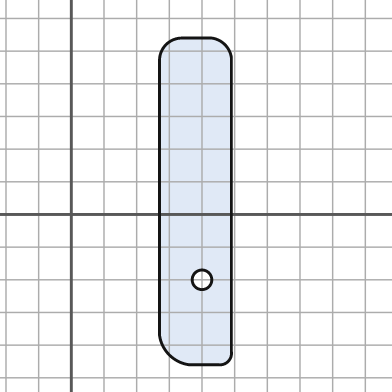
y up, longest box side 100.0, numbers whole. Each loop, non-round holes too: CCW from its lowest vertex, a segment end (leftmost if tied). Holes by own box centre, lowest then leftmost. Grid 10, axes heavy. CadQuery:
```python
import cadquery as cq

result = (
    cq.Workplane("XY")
    .moveTo(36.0, -46.0)
    .lineTo(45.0, -46.0)
    .threePointArc((48.0, -45.0), (49.0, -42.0))
    .lineTo(49.0, 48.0)
    .threePointArc((47.0, 52.0), (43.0, 54.0))
    .lineTo(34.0, 54.0)
    .threePointArc((29.0, 52.0), (27.0, 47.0))
    .lineTo(27.0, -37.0)
    .threePointArc((30.0, -43.0), (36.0, -46.0))
    .close()
    .moveTo(40.0, -20.0)
    .circle(3.0)
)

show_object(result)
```